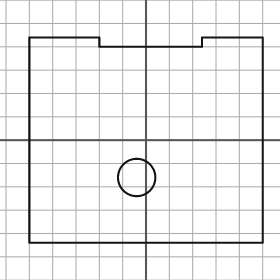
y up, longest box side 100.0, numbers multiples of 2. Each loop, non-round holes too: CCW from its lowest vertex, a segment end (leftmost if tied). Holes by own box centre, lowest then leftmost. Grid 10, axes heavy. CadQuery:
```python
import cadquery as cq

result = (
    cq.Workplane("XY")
    .moveTo(-50.0, -44.0)
    .lineTo(50.0, -44.0)
    .lineTo(50.0, 44.0)
    .lineTo(24.0, 44.0)
    .lineTo(24.0, 40.0)
    .lineTo(-20.0, 40.0)
    .lineTo(-20.0, 44.0)
    .lineTo(-50.0, 44.0)
    .close()
    .moveTo(-4.0, -16.0)
    .circle(8.0)
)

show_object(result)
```